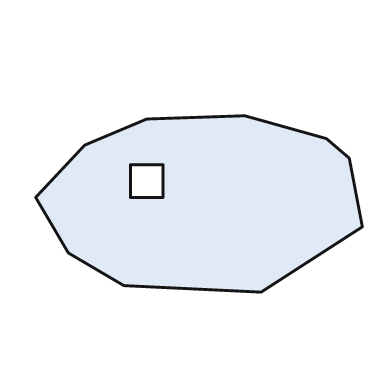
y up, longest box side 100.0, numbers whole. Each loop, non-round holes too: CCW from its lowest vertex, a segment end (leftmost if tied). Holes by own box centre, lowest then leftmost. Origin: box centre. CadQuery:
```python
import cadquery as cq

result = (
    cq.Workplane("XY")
    .moveTo(19.0, -27.0)
    .lineTo(50.0, -7.0)
    .lineTo(46.0, 14.0)
    .lineTo(39.0, 20.0)
    .lineTo(14.0, 27.0)
    .lineTo(-16.0, 26.0)
    .lineTo(-35.0, 18.0)
    .lineTo(-50.0, 2.0)
    .lineTo(-40.0, -15.0)
    .lineTo(-23.0, -25.0)
    .close()
    .moveTo(-21.0, 2.0)
    .lineTo(-11.0, 2.0)
    .lineTo(-11.0, 12.0)
    .lineTo(-21.0, 12.0)
    .close()
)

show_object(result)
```